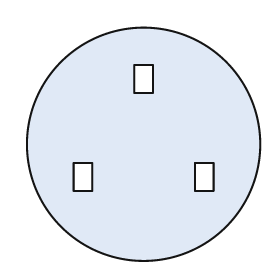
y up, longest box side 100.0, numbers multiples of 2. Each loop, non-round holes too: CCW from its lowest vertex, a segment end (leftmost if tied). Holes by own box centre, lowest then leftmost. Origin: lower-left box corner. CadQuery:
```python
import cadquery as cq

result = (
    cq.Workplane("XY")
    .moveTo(50.0, 50.0)
    .circle(50.0)
    .moveTo(20.0, 30.0)
    .lineTo(28.0, 30.0)
    .lineTo(28.0, 42.0)
    .lineTo(20.0, 42.0)
    .close()
    .moveTo(72.0, 30.0)
    .lineTo(80.0, 30.0)
    .lineTo(80.0, 42.0)
    .lineTo(72.0, 42.0)
    .close()
    .moveTo(46.0, 72.0)
    .lineTo(54.0, 72.0)
    .lineTo(54.0, 84.0)
    .lineTo(46.0, 84.0)
    .close()
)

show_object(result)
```